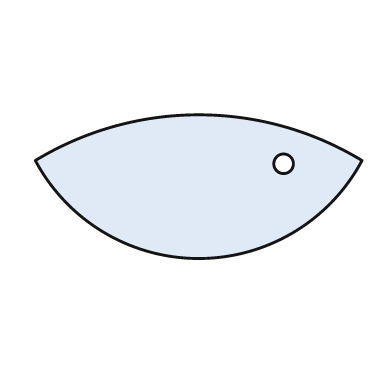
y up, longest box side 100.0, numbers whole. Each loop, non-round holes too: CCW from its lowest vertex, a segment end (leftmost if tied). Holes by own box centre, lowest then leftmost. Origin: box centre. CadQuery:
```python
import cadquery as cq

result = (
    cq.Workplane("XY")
    .moveTo(-50.0, 8.0)
    .threePointArc((0.0, -22.0), (50.0, 8.0))
    .threePointArc((0.0, 22.0), (-50.0, 8.0))
    .close()
    .moveTo(26.0, 7.0)
    .circle(3.0)
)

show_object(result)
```